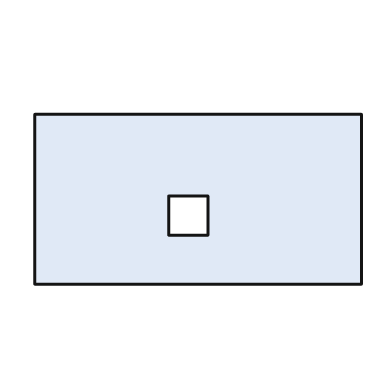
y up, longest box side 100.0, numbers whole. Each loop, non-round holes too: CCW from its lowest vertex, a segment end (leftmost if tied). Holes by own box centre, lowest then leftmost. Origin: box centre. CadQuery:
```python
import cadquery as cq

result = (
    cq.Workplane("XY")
    .moveTo(-50.0, -26.0)
    .lineTo(50.0, -26.0)
    .lineTo(50.0, 26.0)
    .lineTo(-50.0, 26.0)
    .close()
    .moveTo(-9.0, -11.0)
    .lineTo(3.0, -11.0)
    .lineTo(3.0, 1.0)
    .lineTo(-9.0, 1.0)
    .close()
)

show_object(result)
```